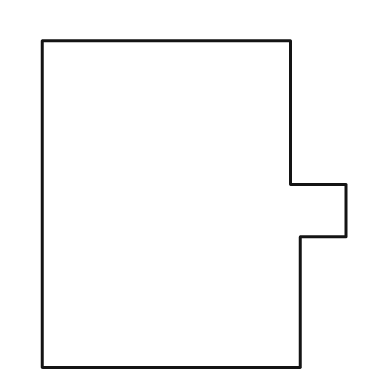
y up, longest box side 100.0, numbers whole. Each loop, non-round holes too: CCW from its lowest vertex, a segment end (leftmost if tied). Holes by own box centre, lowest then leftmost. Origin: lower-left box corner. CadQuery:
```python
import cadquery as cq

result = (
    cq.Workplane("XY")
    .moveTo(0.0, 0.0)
    .lineTo(79.0, 0.0)
    .lineTo(79.0, 40.0)
    .lineTo(93.0, 40.0)
    .lineTo(93.0, 56.0)
    .lineTo(76.0, 56.0)
    .lineTo(76.0, 100.0)
    .lineTo(0.0, 100.0)
    .close()
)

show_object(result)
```